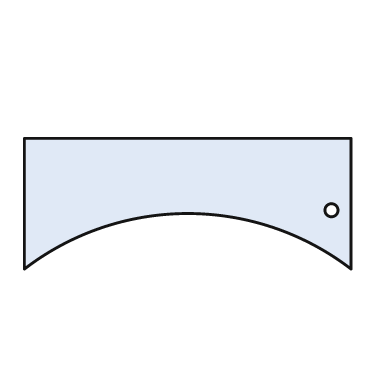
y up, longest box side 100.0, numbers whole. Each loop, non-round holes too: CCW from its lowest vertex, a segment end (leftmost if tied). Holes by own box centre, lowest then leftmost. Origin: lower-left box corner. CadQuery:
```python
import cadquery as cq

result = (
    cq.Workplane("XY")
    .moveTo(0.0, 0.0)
    .threePointArc((50.0, 17.0), (100.0, 0.0))
    .lineTo(100.0, 40.0)
    .lineTo(0.0, 40.0)
    .close()
    .moveTo(94.0, 18.0)
    .circle(2.0)
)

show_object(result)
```